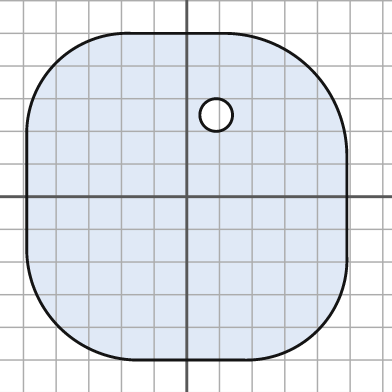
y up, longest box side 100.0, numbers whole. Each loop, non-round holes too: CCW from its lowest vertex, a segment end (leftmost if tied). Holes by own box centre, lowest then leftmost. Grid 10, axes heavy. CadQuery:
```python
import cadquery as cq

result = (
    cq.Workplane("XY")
    .moveTo(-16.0, -50.0)
    .lineTo(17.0, -50.0)
    .threePointArc((40.0, -41.0), (49.0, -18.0))
    .lineTo(49.0, 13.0)
    .threePointArc((38.0, 39.0), (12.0, 50.0))
    .lineTo(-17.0, 50.0)
    .threePointArc((-40.0, 41.0), (-49.0, 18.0))
    .lineTo(-49.0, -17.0)
    .threePointArc((-39.0, -40.0), (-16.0, -50.0))
    .close()
    .moveTo(9.0, 25.0)
    .circle(5.0)
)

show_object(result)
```